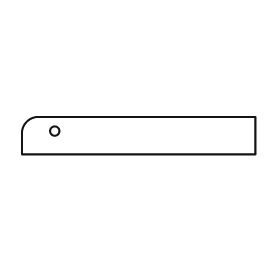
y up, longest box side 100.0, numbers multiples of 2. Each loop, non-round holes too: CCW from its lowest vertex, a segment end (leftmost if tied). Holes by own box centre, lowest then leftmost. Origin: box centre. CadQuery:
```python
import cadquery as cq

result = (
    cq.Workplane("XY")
    .moveTo(-50.0, -8.0)
    .lineTo(50.0, -8.0)
    .lineTo(50.0, 8.0)
    .lineTo(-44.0, 8.0)
    .threePointArc((-48.0, 6.0), (-50.0, 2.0))
    .close()
    .moveTo(-36.0, 2.0)
    .circle(2.0)
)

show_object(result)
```